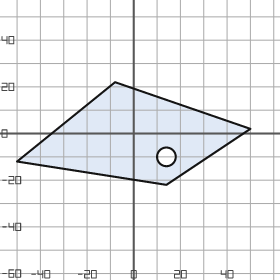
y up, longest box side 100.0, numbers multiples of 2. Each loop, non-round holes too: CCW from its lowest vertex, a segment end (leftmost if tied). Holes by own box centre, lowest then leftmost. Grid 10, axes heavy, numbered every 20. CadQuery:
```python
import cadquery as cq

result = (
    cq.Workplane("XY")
    .moveTo(14.0, -22.0)
    .lineTo(50.0, 2.0)
    .lineTo(-8.0, 22.0)
    .lineTo(-50.0, -12.0)
    .close()
    .moveTo(14.0, -10.0)
    .circle(4.0)
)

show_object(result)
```